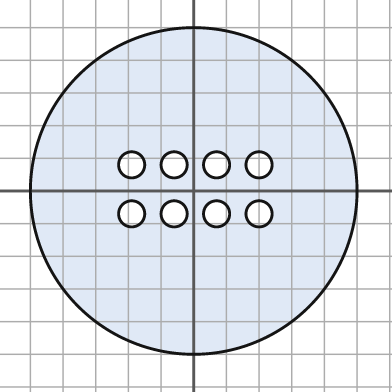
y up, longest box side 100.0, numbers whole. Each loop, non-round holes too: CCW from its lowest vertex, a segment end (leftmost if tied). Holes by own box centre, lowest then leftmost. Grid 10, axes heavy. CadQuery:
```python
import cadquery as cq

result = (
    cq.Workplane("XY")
    .moveTo(0.0, 0.0)
    .circle(50.0)
    .moveTo(-19.0, -7.0)
    .circle(4.0)
    .moveTo(-6.0, -7.0)
    .circle(4.0)
    .moveTo(7.0, -7.0)
    .circle(4.0)
    .moveTo(20.0, -7.0)
    .circle(4.0)
    .moveTo(-19.0, 8.0)
    .circle(4.0)
    .moveTo(-6.0, 8.0)
    .circle(4.0)
    .moveTo(7.0, 8.0)
    .circle(4.0)
    .moveTo(20.0, 8.0)
    .circle(4.0)
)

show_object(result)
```